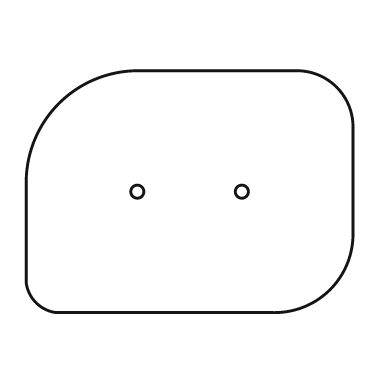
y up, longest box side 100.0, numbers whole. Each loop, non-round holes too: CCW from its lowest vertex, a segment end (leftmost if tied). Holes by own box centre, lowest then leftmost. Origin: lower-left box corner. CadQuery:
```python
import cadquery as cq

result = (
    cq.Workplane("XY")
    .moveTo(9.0, 0.0)
    .lineTo(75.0, 0.0)
    .threePointArc((93.0, 7.0), (100.0, 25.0))
    .lineTo(100.0, 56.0)
    .threePointArc((95.0, 69.0), (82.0, 74.0))
    .lineTo(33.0, 74.0)
    .threePointArc((10.0, 64.0), (0.0, 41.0))
    .lineTo(0.0, 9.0)
    .threePointArc((3.0, 3.0), (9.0, 0.0))
    .close()
    .moveTo(34.0, 37.0)
    .circle(2.0)
    .moveTo(66.0, 37.0)
    .circle(2.0)
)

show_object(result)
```